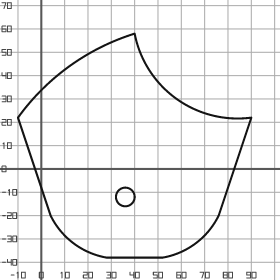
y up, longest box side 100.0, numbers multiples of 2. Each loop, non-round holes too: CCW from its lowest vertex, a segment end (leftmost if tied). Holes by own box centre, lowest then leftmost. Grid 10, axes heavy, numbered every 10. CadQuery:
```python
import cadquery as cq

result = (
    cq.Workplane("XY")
    .moveTo(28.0, -38.0)
    .lineTo(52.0, -38.0)
    .threePointArc((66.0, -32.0), (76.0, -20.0))
    .lineTo(90.0, 22.0)
    .threePointArc((58.0, 30.0), (40.0, 58.0))
    .threePointArc((12.0, 44.0), (-10.0, 22.0))
    .lineTo(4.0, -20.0)
    .threePointArc((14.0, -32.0), (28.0, -38.0))
    .close()
    .moveTo(36.0, -12.0)
    .circle(4.0)
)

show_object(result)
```